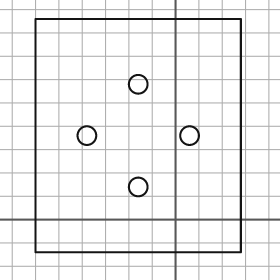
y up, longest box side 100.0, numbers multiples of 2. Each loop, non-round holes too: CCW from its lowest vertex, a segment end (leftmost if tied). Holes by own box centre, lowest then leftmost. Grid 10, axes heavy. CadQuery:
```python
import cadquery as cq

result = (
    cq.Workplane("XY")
    .moveTo(-60.0, -14.0)
    .lineTo(28.0, -14.0)
    .lineTo(28.0, 86.0)
    .lineTo(-60.0, 86.0)
    .close()
    .moveTo(-16.0, 14.0)
    .circle(4.0)
    .moveTo(-38.0, 36.0)
    .circle(4.0)
    .moveTo(6.0, 36.0)
    .circle(4.0)
    .moveTo(-16.0, 58.0)
    .circle(4.0)
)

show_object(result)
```